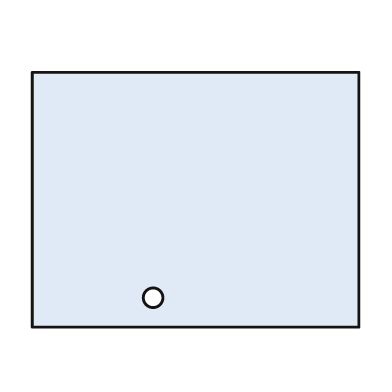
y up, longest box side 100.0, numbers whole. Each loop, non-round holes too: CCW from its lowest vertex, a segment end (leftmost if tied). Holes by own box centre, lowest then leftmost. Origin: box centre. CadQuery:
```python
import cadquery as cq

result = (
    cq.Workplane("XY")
    .moveTo(-50.0, -39.0)
    .lineTo(50.0, -39.0)
    .lineTo(50.0, 39.0)
    .lineTo(-50.0, 39.0)
    .close()
    .moveTo(-13.0, -30.0)
    .circle(3.0)
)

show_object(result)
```